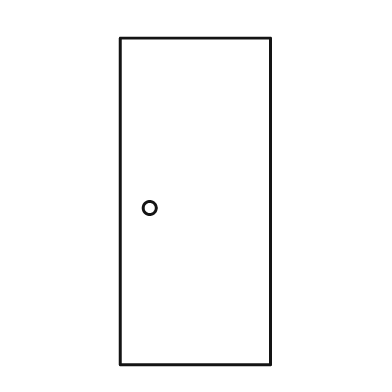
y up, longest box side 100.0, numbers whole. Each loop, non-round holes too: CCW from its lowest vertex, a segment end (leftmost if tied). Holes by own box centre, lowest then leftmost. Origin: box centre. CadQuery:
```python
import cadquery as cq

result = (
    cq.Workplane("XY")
    .moveTo(-23.0, -50.0)
    .lineTo(23.0, -50.0)
    .lineTo(23.0, 50.0)
    .lineTo(-23.0, 50.0)
    .close()
    .moveTo(-14.0, -2.0)
    .circle(2.0)
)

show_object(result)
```